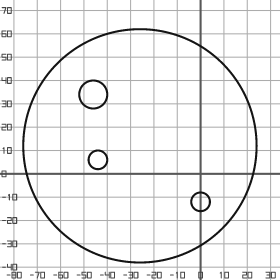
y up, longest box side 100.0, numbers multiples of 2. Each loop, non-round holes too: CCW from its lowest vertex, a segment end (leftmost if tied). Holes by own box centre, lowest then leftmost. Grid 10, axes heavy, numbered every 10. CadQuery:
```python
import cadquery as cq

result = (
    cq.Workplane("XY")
    .moveTo(-26.0, 12.0)
    .circle(50.0)
    .moveTo(0.0, -12.0)
    .circle(4.0)
    .moveTo(-44.0, 6.0)
    .circle(4.0)
    .moveTo(-46.0, 34.0)
    .circle(6.0)
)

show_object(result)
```